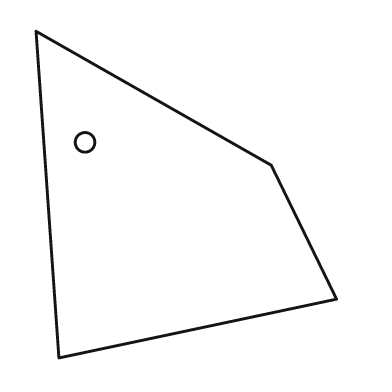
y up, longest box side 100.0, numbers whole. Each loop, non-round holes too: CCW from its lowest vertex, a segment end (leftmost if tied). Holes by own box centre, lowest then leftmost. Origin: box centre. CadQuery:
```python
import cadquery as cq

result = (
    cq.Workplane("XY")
    .moveTo(-39.0, -50.0)
    .lineTo(46.0, -32.0)
    .lineTo(26.0, 9.0)
    .lineTo(-46.0, 50.0)
    .close()
    .moveTo(-31.0, 16.0)
    .circle(3.0)
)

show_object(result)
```